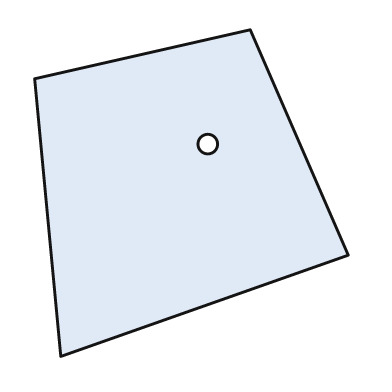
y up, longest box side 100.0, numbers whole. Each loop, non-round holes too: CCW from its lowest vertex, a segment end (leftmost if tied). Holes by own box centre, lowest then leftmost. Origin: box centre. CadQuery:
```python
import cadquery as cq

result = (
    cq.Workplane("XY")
    .moveTo(-40.0, -50.0)
    .lineTo(48.0, -19.0)
    .lineTo(18.0, 50.0)
    .lineTo(-48.0, 35.0)
    .close()
    .moveTo(5.0, 15.0)
    .circle(3.0)
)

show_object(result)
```